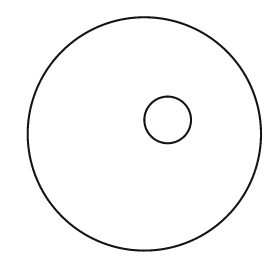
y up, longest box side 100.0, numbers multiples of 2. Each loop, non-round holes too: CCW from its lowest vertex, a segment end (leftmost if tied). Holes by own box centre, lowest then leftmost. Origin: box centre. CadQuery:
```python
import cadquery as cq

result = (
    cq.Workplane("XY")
    .moveTo(0.0, 0.0)
    .circle(50.0)
    .moveTo(10.0, 6.0)
    .circle(10.0)
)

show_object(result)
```